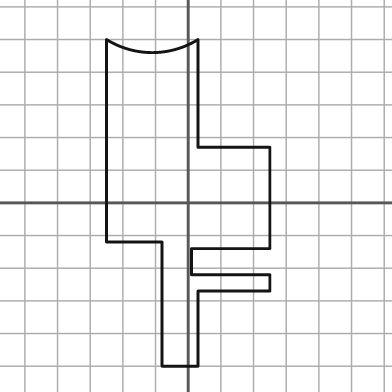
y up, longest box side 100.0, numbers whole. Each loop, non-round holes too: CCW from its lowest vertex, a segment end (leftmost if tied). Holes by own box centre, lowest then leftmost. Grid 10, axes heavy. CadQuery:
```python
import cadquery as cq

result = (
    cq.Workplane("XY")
    .moveTo(-8.0, -50.0)
    .lineTo(3.0, -50.0)
    .lineTo(3.0, -27.0)
    .lineTo(25.0, -27.0)
    .lineTo(25.0, -22.0)
    .lineTo(1.0, -22.0)
    .lineTo(1.0, -14.0)
    .lineTo(25.0, -14.0)
    .lineTo(25.0, 17.0)
    .lineTo(3.0, 17.0)
    .lineTo(3.0, 50.0)
    .threePointArc((-11.0, 46.0), (-25.0, 50.0))
    .lineTo(-25.0, -12.0)
    .lineTo(-8.0, -12.0)
    .close()
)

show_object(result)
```